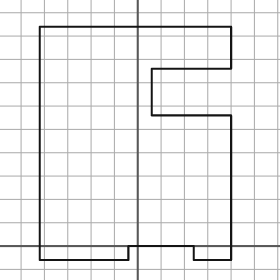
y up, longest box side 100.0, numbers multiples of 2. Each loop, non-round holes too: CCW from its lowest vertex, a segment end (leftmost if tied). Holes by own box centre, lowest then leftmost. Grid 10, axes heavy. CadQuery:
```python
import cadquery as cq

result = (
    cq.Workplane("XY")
    .moveTo(-42.0, -6.0)
    .lineTo(-4.0, -6.0)
    .lineTo(-4.0, 0.0)
    .lineTo(24.0, 0.0)
    .lineTo(24.0, -6.0)
    .lineTo(40.0, -6.0)
    .lineTo(40.0, 56.0)
    .lineTo(6.0, 56.0)
    .lineTo(6.0, 76.0)
    .lineTo(40.0, 76.0)
    .lineTo(40.0, 94.0)
    .lineTo(-42.0, 94.0)
    .close()
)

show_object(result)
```